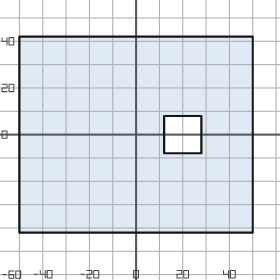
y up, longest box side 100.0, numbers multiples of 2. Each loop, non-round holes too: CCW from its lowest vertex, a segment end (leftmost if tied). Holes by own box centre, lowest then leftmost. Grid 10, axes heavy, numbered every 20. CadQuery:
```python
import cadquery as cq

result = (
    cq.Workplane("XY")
    .moveTo(-50.0, -42.0)
    .lineTo(50.0, -42.0)
    .lineTo(50.0, 42.0)
    .lineTo(-50.0, 42.0)
    .close()
    .moveTo(12.0, -8.0)
    .lineTo(28.0, -8.0)
    .lineTo(28.0, 8.0)
    .lineTo(12.0, 8.0)
    .close()
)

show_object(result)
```